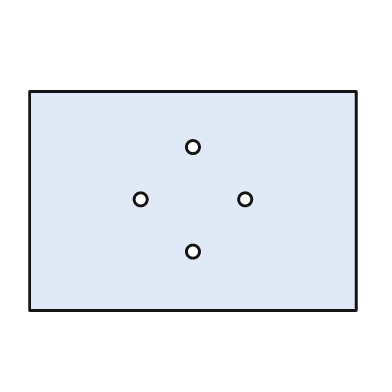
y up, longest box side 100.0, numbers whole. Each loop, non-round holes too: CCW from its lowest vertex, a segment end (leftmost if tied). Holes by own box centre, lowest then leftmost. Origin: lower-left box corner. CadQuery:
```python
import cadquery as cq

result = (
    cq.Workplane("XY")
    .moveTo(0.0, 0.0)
    .lineTo(100.0, 0.0)
    .lineTo(100.0, 67.0)
    .lineTo(0.0, 67.0)
    .close()
    .moveTo(50.0, 18.0)
    .circle(2.0)
    .moveTo(34.0, 34.0)
    .circle(2.0)
    .moveTo(66.0, 34.0)
    .circle(2.0)
    .moveTo(50.0, 50.0)
    .circle(2.0)
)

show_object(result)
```